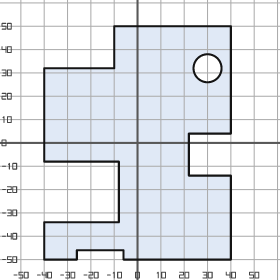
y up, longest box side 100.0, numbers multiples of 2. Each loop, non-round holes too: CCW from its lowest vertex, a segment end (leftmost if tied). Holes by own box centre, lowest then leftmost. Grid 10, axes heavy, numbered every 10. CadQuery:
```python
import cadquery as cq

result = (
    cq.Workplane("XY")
    .moveTo(-40.0, -50.0)
    .lineTo(-26.0, -50.0)
    .lineTo(-26.0, -46.0)
    .lineTo(-6.0, -46.0)
    .lineTo(-6.0, -50.0)
    .lineTo(40.0, -50.0)
    .lineTo(40.0, -14.0)
    .lineTo(22.0, -14.0)
    .lineTo(22.0, 4.0)
    .lineTo(40.0, 4.0)
    .lineTo(40.0, 50.0)
    .lineTo(-10.0, 50.0)
    .lineTo(-10.0, 32.0)
    .lineTo(-40.0, 32.0)
    .lineTo(-40.0, -8.0)
    .lineTo(-8.0, -8.0)
    .lineTo(-8.0, -34.0)
    .lineTo(-40.0, -34.0)
    .close()
    .moveTo(30.0, 32.0)
    .circle(6.0)
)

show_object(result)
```